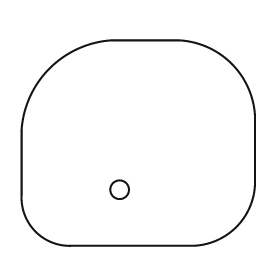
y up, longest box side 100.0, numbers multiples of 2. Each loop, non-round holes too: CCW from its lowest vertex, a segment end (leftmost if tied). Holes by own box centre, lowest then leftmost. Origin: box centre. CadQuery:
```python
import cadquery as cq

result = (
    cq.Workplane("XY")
    .moveTo(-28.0, -44.0)
    .lineTo(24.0, -44.0)
    .threePointArc((42.0, -36.0), (50.0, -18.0))
    .lineTo(50.0, 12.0)
    .threePointArc((40.0, 34.0), (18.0, 44.0))
    .lineTo(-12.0, 44.0)
    .threePointArc((-38.0, 32.0), (-50.0, 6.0))
    .lineTo(-50.0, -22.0)
    .threePointArc((-44.0, -38.0), (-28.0, -44.0))
    .close()
    .moveTo(-8.0, -20.0)
    .circle(4.0)
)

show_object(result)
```